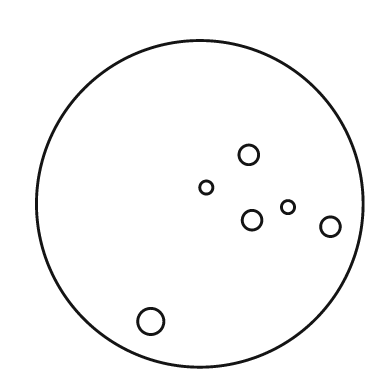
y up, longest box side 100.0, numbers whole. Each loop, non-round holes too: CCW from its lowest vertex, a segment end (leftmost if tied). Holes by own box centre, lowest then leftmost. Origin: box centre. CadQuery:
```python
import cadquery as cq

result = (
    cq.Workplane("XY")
    .moveTo(0.0, 0.0)
    .circle(50.0)
    .moveTo(-15.0, -36.0)
    .circle(4.0)
    .moveTo(40.0, -7.0)
    .circle(3.0)
    .moveTo(16.0, -5.0)
    .circle(3.0)
    .moveTo(27.0, -1.0)
    .circle(2.0)
    .moveTo(2.0, 5.0)
    .circle(2.0)
    .moveTo(15.0, 15.0)
    .circle(3.0)
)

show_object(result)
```